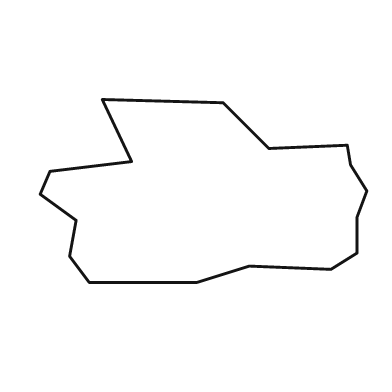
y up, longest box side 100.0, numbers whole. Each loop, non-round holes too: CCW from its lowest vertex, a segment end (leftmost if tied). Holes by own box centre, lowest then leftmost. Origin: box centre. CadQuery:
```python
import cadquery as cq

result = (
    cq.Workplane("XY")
    .moveTo(-35.0, -28.0)
    .lineTo(-2.0, -28.0)
    .lineTo(14.0, -23.0)
    .lineTo(39.0, -24.0)
    .lineTo(47.0, -19.0)
    .lineTo(47.0, -8.0)
    .lineTo(50.0, 0.0)
    .lineTo(45.0, 8.0)
    .lineTo(44.0, 14.0)
    .lineTo(20.0, 13.0)
    .lineTo(6.0, 27.0)
    .lineTo(-31.0, 28.0)
    .lineTo(-22.0, 9.0)
    .lineTo(-47.0, 6.0)
    .lineTo(-50.0, -1.0)
    .lineTo(-39.0, -9.0)
    .lineTo(-41.0, -20.0)
    .close()
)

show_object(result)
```